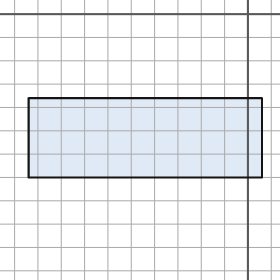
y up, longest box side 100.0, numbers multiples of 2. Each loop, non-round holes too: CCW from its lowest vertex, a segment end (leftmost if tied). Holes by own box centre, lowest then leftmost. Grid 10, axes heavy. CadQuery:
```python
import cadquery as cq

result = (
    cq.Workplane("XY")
    .moveTo(-94.0, -70.0)
    .lineTo(6.0, -70.0)
    .lineTo(6.0, -36.0)
    .lineTo(-94.0, -36.0)
    .close()
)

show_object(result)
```